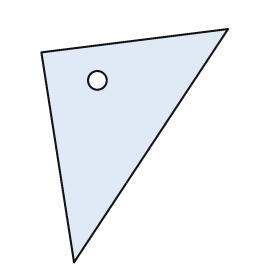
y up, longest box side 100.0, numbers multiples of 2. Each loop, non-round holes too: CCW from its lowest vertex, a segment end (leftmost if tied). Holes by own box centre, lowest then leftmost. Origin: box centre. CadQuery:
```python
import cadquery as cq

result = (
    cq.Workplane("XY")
    .moveTo(-26.0, -50.0)
    .lineTo(40.0, 50.0)
    .lineTo(-40.0, 40.0)
    .close()
    .moveTo(-16.0, 28.0)
    .circle(4.0)
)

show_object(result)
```